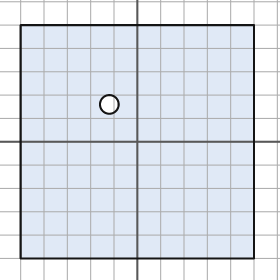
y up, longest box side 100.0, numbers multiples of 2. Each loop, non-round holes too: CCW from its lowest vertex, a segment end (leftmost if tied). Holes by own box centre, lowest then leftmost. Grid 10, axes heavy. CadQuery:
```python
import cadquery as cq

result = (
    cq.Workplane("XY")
    .moveTo(-50.0, -50.0)
    .lineTo(50.0, -50.0)
    .lineTo(50.0, 50.0)
    .lineTo(-50.0, 50.0)
    .close()
    .moveTo(-12.0, 16.0)
    .circle(4.0)
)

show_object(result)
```